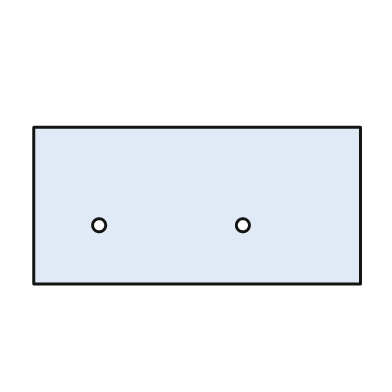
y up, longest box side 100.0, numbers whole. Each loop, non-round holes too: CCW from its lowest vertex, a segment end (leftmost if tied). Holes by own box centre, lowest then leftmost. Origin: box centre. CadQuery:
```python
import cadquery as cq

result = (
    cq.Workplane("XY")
    .moveTo(-50.0, -24.0)
    .lineTo(50.0, -24.0)
    .lineTo(50.0, 24.0)
    .lineTo(-50.0, 24.0)
    .close()
    .moveTo(-30.0, -6.0)
    .circle(2.0)
    .moveTo(14.0, -6.0)
    .circle(2.0)
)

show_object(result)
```